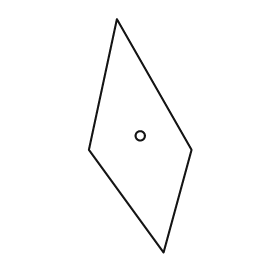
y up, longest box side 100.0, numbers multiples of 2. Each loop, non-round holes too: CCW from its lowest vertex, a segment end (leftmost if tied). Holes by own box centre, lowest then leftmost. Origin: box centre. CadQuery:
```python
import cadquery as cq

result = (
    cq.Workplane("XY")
    .moveTo(10.0, -50.0)
    .lineTo(22.0, -6.0)
    .lineTo(-10.0, 50.0)
    .lineTo(-22.0, -6.0)
    .close()
    .moveTo(0.0, 0.0)
    .circle(2.0)
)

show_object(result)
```